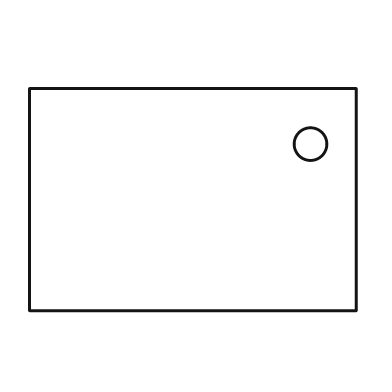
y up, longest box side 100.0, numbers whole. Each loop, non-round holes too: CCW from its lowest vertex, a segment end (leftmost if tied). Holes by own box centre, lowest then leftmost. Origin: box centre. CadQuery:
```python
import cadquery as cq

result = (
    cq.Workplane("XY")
    .moveTo(-50.0, -34.0)
    .lineTo(50.0, -34.0)
    .lineTo(50.0, 34.0)
    .lineTo(-50.0, 34.0)
    .close()
    .moveTo(36.0, 17.0)
    .circle(5.0)
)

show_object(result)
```